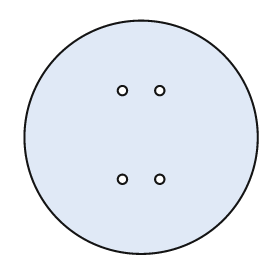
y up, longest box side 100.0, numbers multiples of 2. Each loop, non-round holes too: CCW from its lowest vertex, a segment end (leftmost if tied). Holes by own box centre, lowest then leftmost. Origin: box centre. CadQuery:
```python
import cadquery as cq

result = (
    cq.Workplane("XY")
    .moveTo(0.0, 0.0)
    .circle(50.0)
    .moveTo(-8.0, -18.0)
    .circle(2.0)
    .moveTo(8.0, -18.0)
    .circle(2.0)
    .moveTo(-8.0, 20.0)
    .circle(2.0)
    .moveTo(8.0, 20.0)
    .circle(2.0)
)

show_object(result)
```